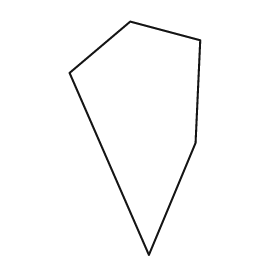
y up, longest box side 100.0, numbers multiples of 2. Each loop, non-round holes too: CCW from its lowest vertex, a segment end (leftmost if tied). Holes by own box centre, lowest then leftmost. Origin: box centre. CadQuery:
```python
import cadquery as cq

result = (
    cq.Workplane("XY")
    .moveTo(6.0, -50.0)
    .lineTo(26.0, -2.0)
    .lineTo(28.0, 42.0)
    .lineTo(-2.0, 50.0)
    .lineTo(-28.0, 28.0)
    .close()
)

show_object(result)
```